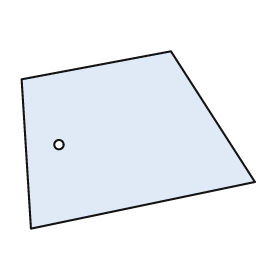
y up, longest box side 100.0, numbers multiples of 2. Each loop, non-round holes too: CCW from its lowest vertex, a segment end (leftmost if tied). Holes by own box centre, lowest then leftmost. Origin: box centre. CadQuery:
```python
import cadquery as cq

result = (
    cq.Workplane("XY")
    .moveTo(-46.0, -38.0)
    .lineTo(50.0, -18.0)
    .lineTo(14.0, 38.0)
    .lineTo(-50.0, 26.0)
    .close()
    .moveTo(-34.0, -2.0)
    .circle(2.0)
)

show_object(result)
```